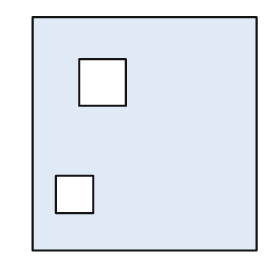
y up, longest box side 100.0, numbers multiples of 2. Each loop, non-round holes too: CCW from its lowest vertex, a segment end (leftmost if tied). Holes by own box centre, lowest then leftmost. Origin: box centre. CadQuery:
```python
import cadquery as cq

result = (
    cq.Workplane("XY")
    .moveTo(-48.0, -50.0)
    .lineTo(48.0, -50.0)
    .lineTo(48.0, 50.0)
    .lineTo(-48.0, 50.0)
    .close()
    .moveTo(-38.0, -34.0)
    .lineTo(-22.0, -34.0)
    .lineTo(-22.0, -18.0)
    .lineTo(-38.0, -18.0)
    .close()
    .moveTo(-28.0, 12.0)
    .lineTo(-8.0, 12.0)
    .lineTo(-8.0, 32.0)
    .lineTo(-28.0, 32.0)
    .close()
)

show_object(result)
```